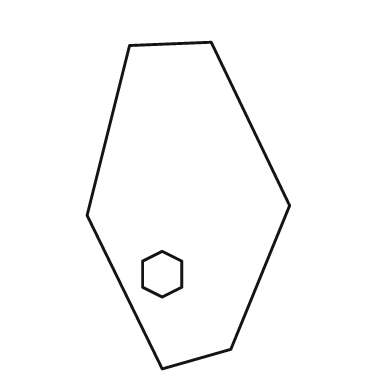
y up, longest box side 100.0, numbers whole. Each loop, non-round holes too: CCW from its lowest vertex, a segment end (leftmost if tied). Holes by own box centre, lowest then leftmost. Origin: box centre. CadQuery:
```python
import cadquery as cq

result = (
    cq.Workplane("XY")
    .moveTo(-8.0, -50.0)
    .lineTo(13.0, -44.0)
    .lineTo(31.0, 0.0)
    .lineTo(7.0, 50.0)
    .lineTo(-18.0, 49.0)
    .lineTo(-31.0, -3.0)
    .close()
    .moveTo(-8.0, -28.0)
    .lineTo(-2.0, -25.0)
    .lineTo(-2.0, -17.0)
    .lineTo(-8.0, -14.0)
    .lineTo(-14.0, -17.0)
    .lineTo(-14.0, -25.0)
    .close()
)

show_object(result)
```